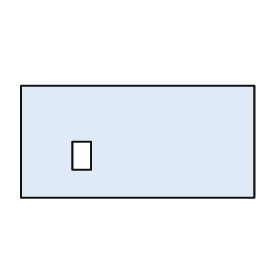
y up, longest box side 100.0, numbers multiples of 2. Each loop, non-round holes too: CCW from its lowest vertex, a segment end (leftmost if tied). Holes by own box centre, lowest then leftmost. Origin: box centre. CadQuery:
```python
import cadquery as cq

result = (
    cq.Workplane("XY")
    .moveTo(-50.0, -24.0)
    .lineTo(50.0, -24.0)
    .lineTo(50.0, 24.0)
    .lineTo(-50.0, 24.0)
    .close()
    .moveTo(-28.0, -12.0)
    .lineTo(-20.0, -12.0)
    .lineTo(-20.0, 0.0)
    .lineTo(-28.0, 0.0)
    .close()
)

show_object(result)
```